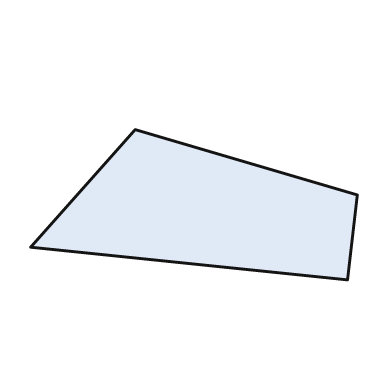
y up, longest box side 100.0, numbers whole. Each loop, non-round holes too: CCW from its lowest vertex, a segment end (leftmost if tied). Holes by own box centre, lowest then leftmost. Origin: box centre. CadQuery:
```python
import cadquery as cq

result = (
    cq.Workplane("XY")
    .moveTo(47.0, -23.0)
    .lineTo(50.0, 3.0)
    .lineTo(-18.0, 23.0)
    .lineTo(-50.0, -13.0)
    .close()
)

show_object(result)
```